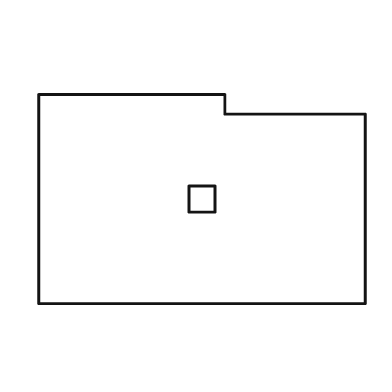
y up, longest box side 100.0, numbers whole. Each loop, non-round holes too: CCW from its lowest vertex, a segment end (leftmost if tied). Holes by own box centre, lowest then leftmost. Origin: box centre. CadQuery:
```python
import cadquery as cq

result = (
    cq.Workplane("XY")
    .moveTo(-50.0, -32.0)
    .lineTo(50.0, -32.0)
    .lineTo(50.0, 26.0)
    .lineTo(7.0, 26.0)
    .lineTo(7.0, 32.0)
    .lineTo(-50.0, 32.0)
    .close()
    .moveTo(-4.0, -4.0)
    .lineTo(4.0, -4.0)
    .lineTo(4.0, 4.0)
    .lineTo(-4.0, 4.0)
    .close()
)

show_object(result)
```